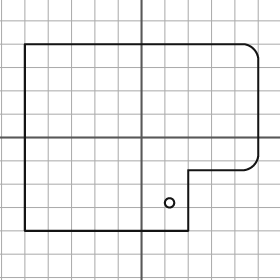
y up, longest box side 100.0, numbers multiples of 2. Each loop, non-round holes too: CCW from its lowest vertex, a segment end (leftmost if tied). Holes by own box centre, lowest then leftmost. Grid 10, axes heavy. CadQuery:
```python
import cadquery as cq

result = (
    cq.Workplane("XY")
    .moveTo(-50.0, -40.0)
    .lineTo(20.0, -40.0)
    .lineTo(20.0, -14.0)
    .lineTo(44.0, -14.0)
    .threePointArc((48.0, -12.0), (50.0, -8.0))
    .lineTo(50.0, 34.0)
    .threePointArc((48.0, 38.0), (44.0, 40.0))
    .lineTo(-50.0, 40.0)
    .close()
    .moveTo(12.0, -28.0)
    .circle(2.0)
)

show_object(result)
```